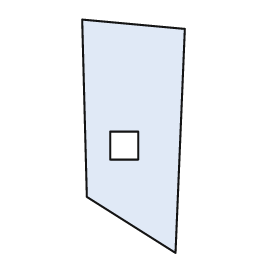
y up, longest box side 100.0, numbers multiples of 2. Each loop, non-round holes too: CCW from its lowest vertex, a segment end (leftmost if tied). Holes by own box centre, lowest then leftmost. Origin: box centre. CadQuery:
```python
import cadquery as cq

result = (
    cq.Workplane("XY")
    .moveTo(18.0, -50.0)
    .lineTo(22.0, 46.0)
    .lineTo(-22.0, 50.0)
    .lineTo(-20.0, -26.0)
    .close()
    .moveTo(-10.0, -10.0)
    .lineTo(2.0, -10.0)
    .lineTo(2.0, 2.0)
    .lineTo(-10.0, 2.0)
    .close()
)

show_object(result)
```